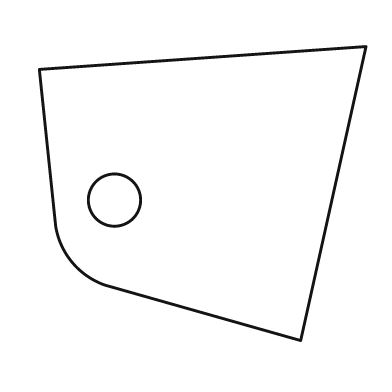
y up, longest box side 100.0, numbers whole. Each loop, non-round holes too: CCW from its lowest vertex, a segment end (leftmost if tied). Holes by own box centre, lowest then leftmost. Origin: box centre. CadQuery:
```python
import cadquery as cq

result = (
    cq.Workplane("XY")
    .moveTo(30.0, -45.0)
    .lineTo(50.0, 45.0)
    .lineTo(-50.0, 38.0)
    .lineTo(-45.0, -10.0)
    .threePointArc((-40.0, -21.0), (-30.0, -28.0))
    .close()
    .moveTo(-27.0, -2.0)
    .circle(8.0)
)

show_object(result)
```